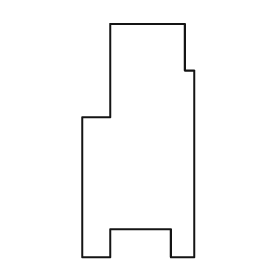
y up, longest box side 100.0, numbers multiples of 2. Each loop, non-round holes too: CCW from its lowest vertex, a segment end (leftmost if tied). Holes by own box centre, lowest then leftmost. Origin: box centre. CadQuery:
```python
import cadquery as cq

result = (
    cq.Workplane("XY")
    .moveTo(-24.0, -50.0)
    .lineTo(-12.0, -50.0)
    .lineTo(-12.0, -38.0)
    .lineTo(14.0, -38.0)
    .lineTo(14.0, -50.0)
    .lineTo(24.0, -50.0)
    .lineTo(24.0, 30.0)
    .lineTo(20.0, 30.0)
    .lineTo(20.0, 50.0)
    .lineTo(-12.0, 50.0)
    .lineTo(-12.0, 10.0)
    .lineTo(-24.0, 10.0)
    .close()
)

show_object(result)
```